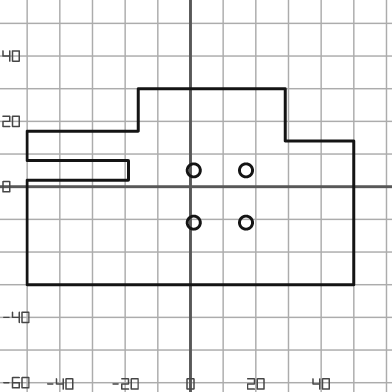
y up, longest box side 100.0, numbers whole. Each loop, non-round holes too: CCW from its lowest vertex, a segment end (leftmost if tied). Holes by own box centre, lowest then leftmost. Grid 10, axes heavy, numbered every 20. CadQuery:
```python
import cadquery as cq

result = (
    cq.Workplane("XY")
    .moveTo(-50.0, -30.0)
    .lineTo(50.0, -30.0)
    .lineTo(50.0, 14.0)
    .lineTo(29.0, 14.0)
    .lineTo(29.0, 30.0)
    .lineTo(-16.0, 30.0)
    .lineTo(-16.0, 17.0)
    .lineTo(-50.0, 17.0)
    .lineTo(-50.0, 8.0)
    .lineTo(-19.0, 8.0)
    .lineTo(-19.0, 2.0)
    .lineTo(-50.0, 2.0)
    .close()
    .moveTo(1.0, -11.0)
    .circle(2.0)
    .moveTo(17.0, -11.0)
    .circle(2.0)
    .moveTo(1.0, 5.0)
    .circle(2.0)
    .moveTo(17.0, 5.0)
    .circle(2.0)
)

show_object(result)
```